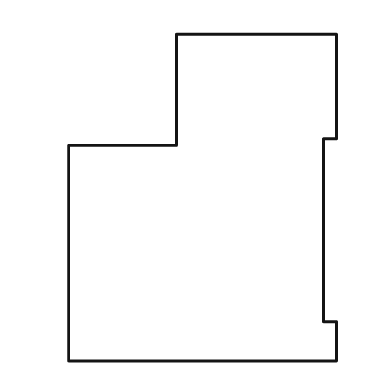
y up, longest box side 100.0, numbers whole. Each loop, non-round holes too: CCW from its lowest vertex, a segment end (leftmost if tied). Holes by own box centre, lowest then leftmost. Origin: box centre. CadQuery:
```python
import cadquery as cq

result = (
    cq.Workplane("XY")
    .moveTo(-41.0, -50.0)
    .lineTo(41.0, -50.0)
    .lineTo(41.0, -38.0)
    .lineTo(37.0, -38.0)
    .lineTo(37.0, 18.0)
    .lineTo(41.0, 18.0)
    .lineTo(41.0, 50.0)
    .lineTo(-8.0, 50.0)
    .lineTo(-8.0, 16.0)
    .lineTo(-41.0, 16.0)
    .close()
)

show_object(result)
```